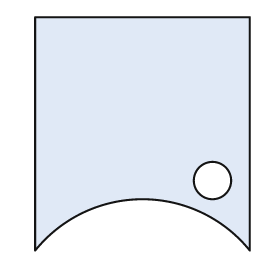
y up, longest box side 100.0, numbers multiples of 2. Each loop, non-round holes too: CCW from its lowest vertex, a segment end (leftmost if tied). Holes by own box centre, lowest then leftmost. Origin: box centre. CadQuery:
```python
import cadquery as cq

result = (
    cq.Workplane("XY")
    .moveTo(-46.0, -50.0)
    .threePointArc((0.0, -28.0), (46.0, -50.0))
    .lineTo(46.0, 50.0)
    .lineTo(-46.0, 50.0)
    .close()
    .moveTo(30.0, -20.0)
    .circle(8.0)
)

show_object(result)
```